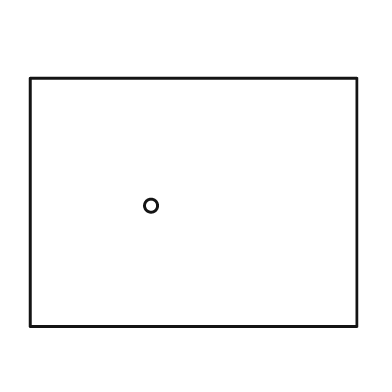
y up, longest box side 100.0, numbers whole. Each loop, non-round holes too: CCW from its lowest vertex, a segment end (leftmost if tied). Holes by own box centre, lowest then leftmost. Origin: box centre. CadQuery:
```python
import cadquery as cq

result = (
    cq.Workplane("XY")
    .moveTo(-50.0, -38.0)
    .lineTo(50.0, -38.0)
    .lineTo(50.0, 38.0)
    .lineTo(-50.0, 38.0)
    .close()
    .moveTo(-13.0, -1.0)
    .circle(2.0)
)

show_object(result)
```